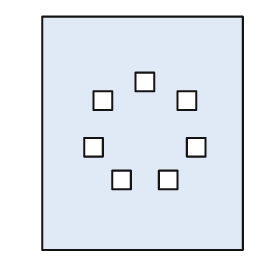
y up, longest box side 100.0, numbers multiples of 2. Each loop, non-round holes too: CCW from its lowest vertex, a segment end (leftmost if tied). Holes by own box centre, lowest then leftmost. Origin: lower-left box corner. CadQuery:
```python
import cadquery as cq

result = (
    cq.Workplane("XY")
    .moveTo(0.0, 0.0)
    .lineTo(86.0, 0.0)
    .lineTo(86.0, 100.0)
    .lineTo(0.0, 100.0)
    .close()
    .moveTo(30.0, 26.0)
    .lineTo(38.0, 26.0)
    .lineTo(38.0, 34.0)
    .lineTo(30.0, 34.0)
    .close()
    .moveTo(50.0, 26.0)
    .lineTo(58.0, 26.0)
    .lineTo(58.0, 34.0)
    .lineTo(50.0, 34.0)
    .close()
    .moveTo(18.0, 40.0)
    .lineTo(26.0, 40.0)
    .lineTo(26.0, 48.0)
    .lineTo(18.0, 48.0)
    .close()
    .moveTo(62.0, 40.0)
    .lineTo(70.0, 40.0)
    .lineTo(70.0, 48.0)
    .lineTo(62.0, 48.0)
    .close()
    .moveTo(22.0, 60.0)
    .lineTo(30.0, 60.0)
    .lineTo(30.0, 68.0)
    .lineTo(22.0, 68.0)
    .close()
    .moveTo(58.0, 60.0)
    .lineTo(66.0, 60.0)
    .lineTo(66.0, 68.0)
    .lineTo(58.0, 68.0)
    .close()
    .moveTo(40.0, 68.0)
    .lineTo(48.0, 68.0)
    .lineTo(48.0, 76.0)
    .lineTo(40.0, 76.0)
    .close()
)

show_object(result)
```